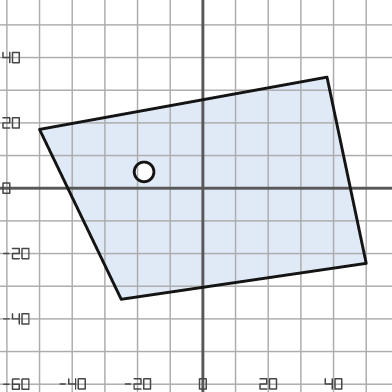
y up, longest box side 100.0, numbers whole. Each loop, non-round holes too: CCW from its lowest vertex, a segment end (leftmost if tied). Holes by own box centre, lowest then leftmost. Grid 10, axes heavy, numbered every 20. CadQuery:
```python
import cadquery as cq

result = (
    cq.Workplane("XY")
    .moveTo(-25.0, -34.0)
    .lineTo(50.0, -23.0)
    .lineTo(38.0, 34.0)
    .lineTo(-50.0, 18.0)
    .close()
    .moveTo(-18.0, 5.0)
    .circle(3.0)
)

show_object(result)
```